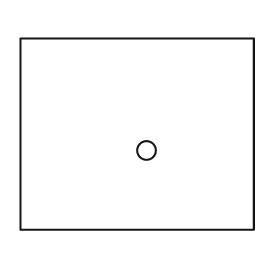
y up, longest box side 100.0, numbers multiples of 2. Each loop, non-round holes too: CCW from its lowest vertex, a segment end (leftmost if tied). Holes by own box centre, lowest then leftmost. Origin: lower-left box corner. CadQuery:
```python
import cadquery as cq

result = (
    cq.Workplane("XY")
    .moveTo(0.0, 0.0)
    .lineTo(100.0, 0.0)
    .lineTo(100.0, 82.0)
    .lineTo(0.0, 82.0)
    .close()
    .moveTo(54.0, 34.0)
    .circle(4.0)
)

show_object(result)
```